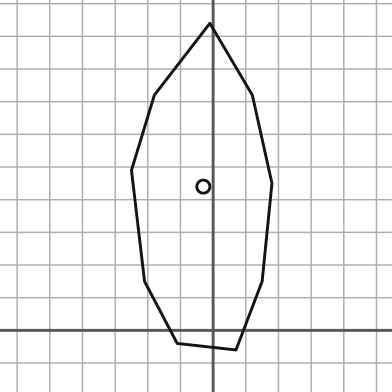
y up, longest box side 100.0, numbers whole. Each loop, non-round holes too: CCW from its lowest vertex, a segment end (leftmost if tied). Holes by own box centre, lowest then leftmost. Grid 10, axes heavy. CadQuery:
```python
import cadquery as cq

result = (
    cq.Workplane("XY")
    .moveTo(7.0, -6.0)
    .lineTo(15.0, 15.0)
    .lineTo(18.0, 45.0)
    .lineTo(12.0, 72.0)
    .lineTo(-1.0, 94.0)
    .lineTo(-18.0, 72.0)
    .lineTo(-25.0, 49.0)
    .lineTo(-21.0, 15.0)
    .lineTo(-11.0, -4.0)
    .close()
    .moveTo(-3.0, 44.0)
    .circle(2.0)
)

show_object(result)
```